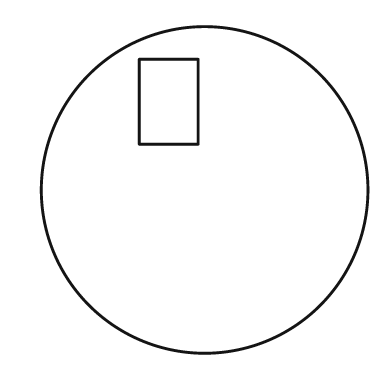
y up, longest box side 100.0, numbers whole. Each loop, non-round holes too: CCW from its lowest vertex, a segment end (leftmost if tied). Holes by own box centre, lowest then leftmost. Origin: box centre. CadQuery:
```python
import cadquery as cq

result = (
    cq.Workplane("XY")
    .moveTo(0.0, 0.0)
    .circle(50.0)
    .moveTo(-20.0, 14.0)
    .lineTo(-2.0, 14.0)
    .lineTo(-2.0, 40.0)
    .lineTo(-20.0, 40.0)
    .close()
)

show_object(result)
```